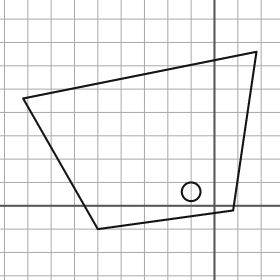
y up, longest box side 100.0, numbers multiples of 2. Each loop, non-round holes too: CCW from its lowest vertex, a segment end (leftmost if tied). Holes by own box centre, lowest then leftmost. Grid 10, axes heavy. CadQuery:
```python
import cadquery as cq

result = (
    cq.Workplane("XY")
    .moveTo(-50.0, -10.0)
    .lineTo(8.0, -2.0)
    .lineTo(18.0, 66.0)
    .lineTo(-82.0, 46.0)
    .close()
    .moveTo(-10.0, 6.0)
    .circle(4.0)
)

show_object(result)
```